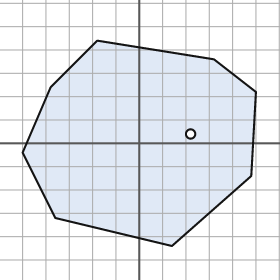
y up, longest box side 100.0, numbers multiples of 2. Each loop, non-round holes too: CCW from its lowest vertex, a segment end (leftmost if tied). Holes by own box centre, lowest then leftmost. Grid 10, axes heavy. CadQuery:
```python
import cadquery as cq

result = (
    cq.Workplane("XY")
    .moveTo(14.0, -44.0)
    .lineTo(48.0, -14.0)
    .lineTo(50.0, 22.0)
    .lineTo(32.0, 36.0)
    .lineTo(-18.0, 44.0)
    .lineTo(-38.0, 24.0)
    .lineTo(-50.0, -4.0)
    .lineTo(-36.0, -32.0)
    .close()
    .moveTo(22.0, 4.0)
    .circle(2.0)
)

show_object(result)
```